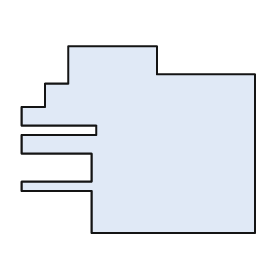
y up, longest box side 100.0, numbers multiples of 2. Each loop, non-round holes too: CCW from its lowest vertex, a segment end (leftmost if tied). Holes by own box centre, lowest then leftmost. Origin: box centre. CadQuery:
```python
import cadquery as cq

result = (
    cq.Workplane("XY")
    .moveTo(-20.0, -40.0)
    .lineTo(50.0, -40.0)
    .lineTo(50.0, 28.0)
    .lineTo(8.0, 28.0)
    .lineTo(8.0, 40.0)
    .lineTo(-30.0, 40.0)
    .lineTo(-30.0, 24.0)
    .lineTo(-40.0, 24.0)
    .lineTo(-40.0, 14.0)
    .lineTo(-50.0, 14.0)
    .lineTo(-50.0, 6.0)
    .lineTo(-18.0, 6.0)
    .lineTo(-18.0, 2.0)
    .lineTo(-50.0, 2.0)
    .lineTo(-50.0, -6.0)
    .lineTo(-20.0, -6.0)
    .lineTo(-20.0, -18.0)
    .lineTo(-50.0, -18.0)
    .lineTo(-50.0, -22.0)
    .lineTo(-20.0, -22.0)
    .close()
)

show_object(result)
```